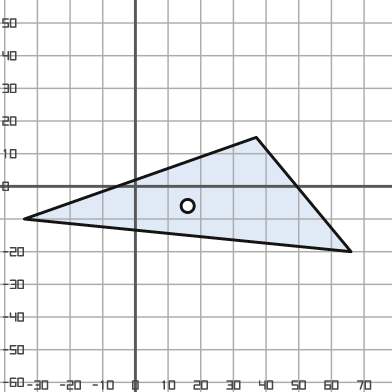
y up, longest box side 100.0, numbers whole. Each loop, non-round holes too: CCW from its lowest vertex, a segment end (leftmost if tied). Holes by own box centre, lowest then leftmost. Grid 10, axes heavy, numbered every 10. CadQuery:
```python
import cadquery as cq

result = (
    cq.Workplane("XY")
    .moveTo(66.0, -20.0)
    .lineTo(37.0, 15.0)
    .lineTo(-34.0, -10.0)
    .close()
    .moveTo(16.0, -6.0)
    .circle(2.0)
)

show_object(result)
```